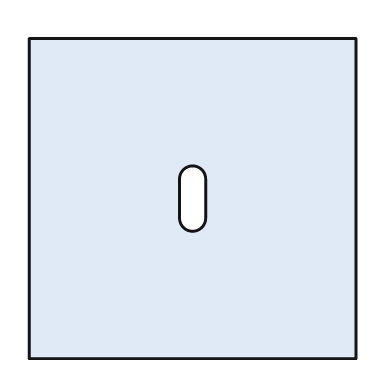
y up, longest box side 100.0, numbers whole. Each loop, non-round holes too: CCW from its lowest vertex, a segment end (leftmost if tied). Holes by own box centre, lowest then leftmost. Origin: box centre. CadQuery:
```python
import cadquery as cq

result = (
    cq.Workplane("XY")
    .moveTo(-50.0, -49.0)
    .lineTo(50.0, -49.0)
    .lineTo(50.0, 49.0)
    .lineTo(-50.0, 49.0)
    .close()
    .moveTo(-4.0, -6.0)
    .threePointArc((0.0, -10.0), (4.0, -6.0))
    .lineTo(4.0, 6.0)
    .threePointArc((0.0, 10.0), (-4.0, 6.0))
    .close()
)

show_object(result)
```